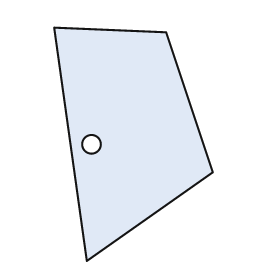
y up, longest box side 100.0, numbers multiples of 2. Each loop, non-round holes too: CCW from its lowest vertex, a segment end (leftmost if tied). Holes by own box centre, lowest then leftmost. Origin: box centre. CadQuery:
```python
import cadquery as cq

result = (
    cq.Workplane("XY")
    .moveTo(-20.0, -50.0)
    .lineTo(34.0, -12.0)
    .lineTo(14.0, 48.0)
    .lineTo(-34.0, 50.0)
    .close()
    .moveTo(-18.0, 0.0)
    .circle(4.0)
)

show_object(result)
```